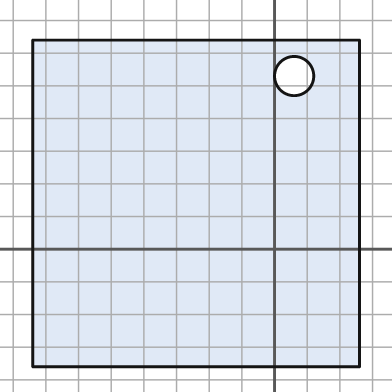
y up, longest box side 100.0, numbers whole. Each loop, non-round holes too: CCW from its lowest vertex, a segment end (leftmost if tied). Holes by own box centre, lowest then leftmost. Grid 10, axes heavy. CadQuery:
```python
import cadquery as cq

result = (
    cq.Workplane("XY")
    .moveTo(-74.0, -36.0)
    .lineTo(26.0, -36.0)
    .lineTo(26.0, 64.0)
    .lineTo(-74.0, 64.0)
    .close()
    .moveTo(6.0, 53.0)
    .circle(6.0)
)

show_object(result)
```